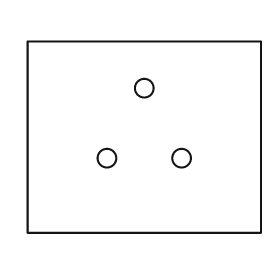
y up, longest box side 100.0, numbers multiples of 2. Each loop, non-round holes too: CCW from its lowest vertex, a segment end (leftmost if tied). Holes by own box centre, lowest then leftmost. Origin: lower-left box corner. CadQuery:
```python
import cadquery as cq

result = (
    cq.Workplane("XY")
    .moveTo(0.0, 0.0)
    .lineTo(100.0, 0.0)
    .lineTo(100.0, 82.0)
    .lineTo(0.0, 82.0)
    .close()
    .moveTo(34.0, 32.0)
    .circle(4.0)
    .moveTo(66.0, 32.0)
    .circle(4.0)
    .moveTo(50.0, 62.0)
    .circle(4.0)
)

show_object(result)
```